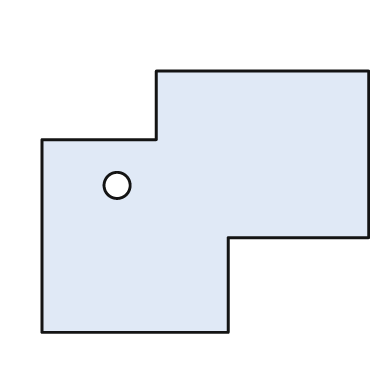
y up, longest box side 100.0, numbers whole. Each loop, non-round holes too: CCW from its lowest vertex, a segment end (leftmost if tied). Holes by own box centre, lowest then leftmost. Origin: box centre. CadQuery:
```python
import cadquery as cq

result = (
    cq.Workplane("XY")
    .moveTo(-50.0, -40.0)
    .lineTo(7.0, -40.0)
    .lineTo(7.0, -11.0)
    .lineTo(50.0, -11.0)
    .lineTo(50.0, 40.0)
    .lineTo(-15.0, 40.0)
    .lineTo(-15.0, 19.0)
    .lineTo(-50.0, 19.0)
    .close()
    .moveTo(-27.0, 5.0)
    .circle(4.0)
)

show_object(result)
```